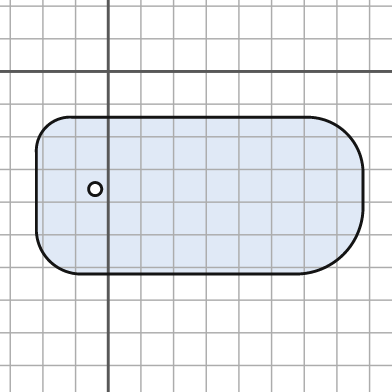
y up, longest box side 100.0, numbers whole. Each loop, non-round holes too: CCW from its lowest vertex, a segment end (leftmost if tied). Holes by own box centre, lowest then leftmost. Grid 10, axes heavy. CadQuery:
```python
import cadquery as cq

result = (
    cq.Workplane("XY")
    .moveTo(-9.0, -62.0)
    .lineTo(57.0, -62.0)
    .threePointArc((72.0, -56.0), (78.0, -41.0))
    .lineTo(78.0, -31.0)
    .threePointArc((73.0, -19.0), (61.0, -14.0))
    .lineTo(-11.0, -14.0)
    .threePointArc((-19.0, -17.0), (-22.0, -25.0))
    .lineTo(-22.0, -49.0)
    .threePointArc((-18.0, -58.0), (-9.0, -62.0))
    .close()
    .moveTo(-4.0, -36.0)
    .circle(2.0)
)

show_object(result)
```